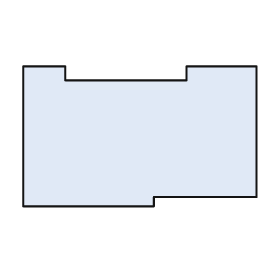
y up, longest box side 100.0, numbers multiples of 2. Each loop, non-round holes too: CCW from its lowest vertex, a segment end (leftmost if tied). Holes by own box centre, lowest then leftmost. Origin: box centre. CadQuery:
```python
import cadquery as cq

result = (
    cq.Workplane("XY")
    .moveTo(-50.0, -30.0)
    .lineTo(6.0, -30.0)
    .lineTo(6.0, -26.0)
    .lineTo(50.0, -26.0)
    .lineTo(50.0, 30.0)
    .lineTo(20.0, 30.0)
    .lineTo(20.0, 24.0)
    .lineTo(-32.0, 24.0)
    .lineTo(-32.0, 30.0)
    .lineTo(-50.0, 30.0)
    .close()
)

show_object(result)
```